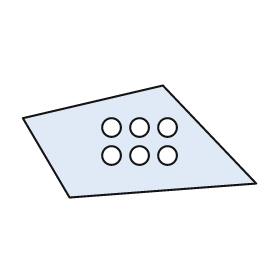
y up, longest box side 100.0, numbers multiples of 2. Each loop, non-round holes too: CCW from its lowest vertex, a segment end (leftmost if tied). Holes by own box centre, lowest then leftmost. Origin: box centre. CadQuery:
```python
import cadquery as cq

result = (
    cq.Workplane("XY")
    .moveTo(-30.0, -24.0)
    .lineTo(50.0, -18.0)
    .lineTo(10.0, 24.0)
    .lineTo(-50.0, 10.0)
    .close()
    .moveTo(-12.0, -6.0)
    .circle(4.0)
    .moveTo(0.0, -6.0)
    .circle(4.0)
    .moveTo(12.0, -6.0)
    .circle(4.0)
    .moveTo(-12.0, 6.0)
    .circle(4.0)
    .moveTo(0.0, 6.0)
    .circle(4.0)
    .moveTo(12.0, 6.0)
    .circle(4.0)
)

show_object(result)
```